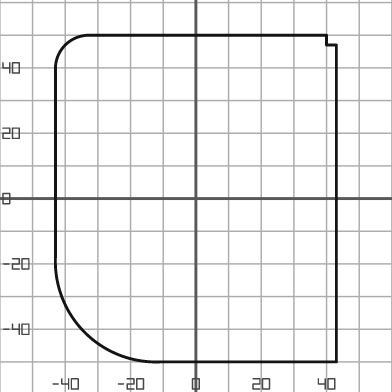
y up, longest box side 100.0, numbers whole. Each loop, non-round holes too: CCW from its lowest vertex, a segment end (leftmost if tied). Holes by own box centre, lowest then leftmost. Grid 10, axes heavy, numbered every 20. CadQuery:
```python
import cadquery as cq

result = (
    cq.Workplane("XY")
    .moveTo(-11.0, -50.0)
    .lineTo(43.0, -50.0)
    .lineTo(43.0, 47.0)
    .lineTo(40.0, 47.0)
    .lineTo(40.0, 50.0)
    .lineTo(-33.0, 50.0)
    .threePointArc((-40.0, 47.0), (-43.0, 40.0))
    .lineTo(-43.0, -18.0)
    .threePointArc((-34.0, -41.0), (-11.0, -50.0))
    .close()
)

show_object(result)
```